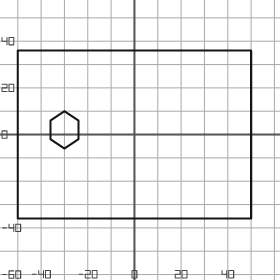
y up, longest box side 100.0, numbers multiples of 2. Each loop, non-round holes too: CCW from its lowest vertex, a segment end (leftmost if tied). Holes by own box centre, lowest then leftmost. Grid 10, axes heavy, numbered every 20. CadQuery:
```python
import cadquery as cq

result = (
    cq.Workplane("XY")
    .moveTo(-50.0, -36.0)
    .lineTo(50.0, -36.0)
    .lineTo(50.0, 36.0)
    .lineTo(-50.0, 36.0)
    .close()
    .moveTo(-30.0, -6.0)
    .lineTo(-24.0, -2.0)
    .lineTo(-24.0, 6.0)
    .lineTo(-30.0, 10.0)
    .lineTo(-36.0, 6.0)
    .lineTo(-36.0, -2.0)
    .close()
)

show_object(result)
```